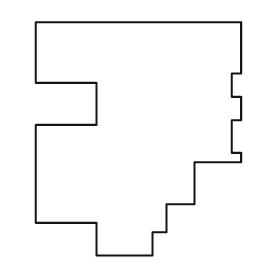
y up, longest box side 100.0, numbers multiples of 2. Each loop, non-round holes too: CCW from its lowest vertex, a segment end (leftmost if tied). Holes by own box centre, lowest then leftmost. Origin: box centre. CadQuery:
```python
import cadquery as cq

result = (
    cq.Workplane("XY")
    .moveTo(-18.0, -50.0)
    .lineTo(6.0, -50.0)
    .lineTo(6.0, -40.0)
    .lineTo(12.0, -40.0)
    .lineTo(12.0, -28.0)
    .lineTo(24.0, -28.0)
    .lineTo(24.0, -10.0)
    .lineTo(44.0, -10.0)
    .lineTo(44.0, -6.0)
    .lineTo(40.0, -6.0)
    .lineTo(40.0, 8.0)
    .lineTo(44.0, 8.0)
    .lineTo(44.0, 18.0)
    .lineTo(40.0, 18.0)
    .lineTo(40.0, 28.0)
    .lineTo(44.0, 28.0)
    .lineTo(44.0, 50.0)
    .lineTo(-44.0, 50.0)
    .lineTo(-44.0, 24.0)
    .lineTo(-18.0, 24.0)
    .lineTo(-18.0, 6.0)
    .lineTo(-44.0, 6.0)
    .lineTo(-44.0, -36.0)
    .lineTo(-18.0, -36.0)
    .close()
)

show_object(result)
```